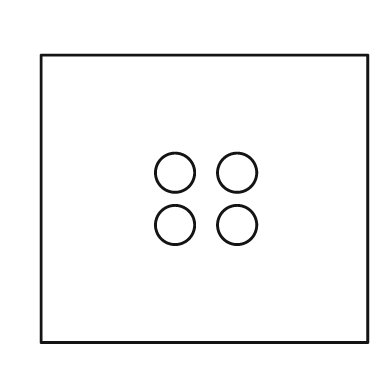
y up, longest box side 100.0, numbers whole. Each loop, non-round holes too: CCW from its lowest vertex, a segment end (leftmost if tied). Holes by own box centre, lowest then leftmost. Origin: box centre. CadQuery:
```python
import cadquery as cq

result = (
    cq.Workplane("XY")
    .moveTo(-50.0, -44.0)
    .lineTo(50.0, -44.0)
    .lineTo(50.0, 44.0)
    .lineTo(-50.0, 44.0)
    .close()
    .moveTo(-9.0, -8.0)
    .circle(6.0)
    .moveTo(10.0, -8.0)
    .circle(6.0)
    .moveTo(-9.0, 8.0)
    .circle(6.0)
    .moveTo(10.0, 8.0)
    .circle(6.0)
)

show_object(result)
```